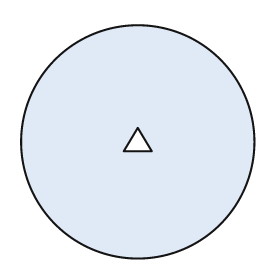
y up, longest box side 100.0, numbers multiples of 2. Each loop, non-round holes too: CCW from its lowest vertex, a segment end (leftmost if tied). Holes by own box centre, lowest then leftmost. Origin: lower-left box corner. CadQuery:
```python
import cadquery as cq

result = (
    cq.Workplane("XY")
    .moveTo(50.0, 50.0)
    .circle(50.0)
    .moveTo(44.0, 46.0)
    .lineTo(56.0, 46.0)
    .lineTo(50.0, 56.0)
    .close()
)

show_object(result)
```